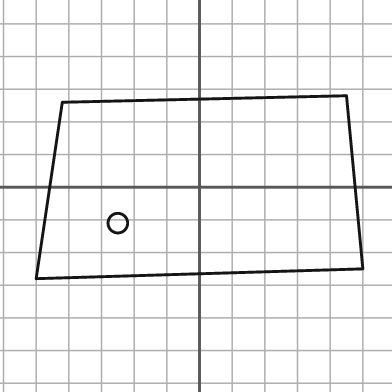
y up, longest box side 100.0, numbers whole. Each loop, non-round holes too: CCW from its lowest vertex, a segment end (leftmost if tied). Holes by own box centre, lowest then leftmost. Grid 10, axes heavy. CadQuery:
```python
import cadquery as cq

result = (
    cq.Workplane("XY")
    .moveTo(-50.0, -28.0)
    .lineTo(50.0, -25.0)
    .lineTo(45.0, 28.0)
    .lineTo(-42.0, 26.0)
    .close()
    .moveTo(-25.0, -11.0)
    .circle(3.0)
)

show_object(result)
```